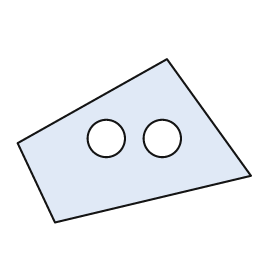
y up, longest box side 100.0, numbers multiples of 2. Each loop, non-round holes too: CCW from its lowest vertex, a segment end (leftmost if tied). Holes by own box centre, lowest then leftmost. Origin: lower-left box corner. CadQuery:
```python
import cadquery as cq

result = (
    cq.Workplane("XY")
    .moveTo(16.0, 0.0)
    .lineTo(100.0, 20.0)
    .lineTo(64.0, 70.0)
    .lineTo(0.0, 34.0)
    .close()
    .moveTo(38.0, 36.0)
    .circle(8.0)
    .moveTo(62.0, 36.0)
    .circle(8.0)
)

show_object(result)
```